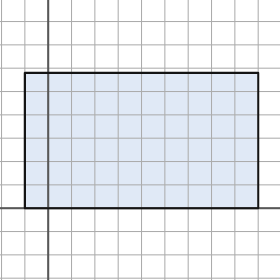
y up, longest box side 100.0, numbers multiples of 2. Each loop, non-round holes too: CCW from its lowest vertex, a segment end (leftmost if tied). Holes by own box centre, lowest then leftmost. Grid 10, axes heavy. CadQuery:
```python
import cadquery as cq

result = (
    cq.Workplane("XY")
    .moveTo(-10.0, 0.0)
    .lineTo(90.0, 0.0)
    .lineTo(90.0, 58.0)
    .lineTo(-10.0, 58.0)
    .close()
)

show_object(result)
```